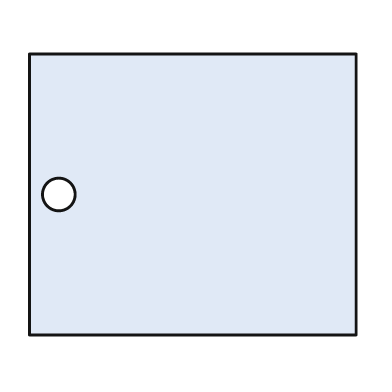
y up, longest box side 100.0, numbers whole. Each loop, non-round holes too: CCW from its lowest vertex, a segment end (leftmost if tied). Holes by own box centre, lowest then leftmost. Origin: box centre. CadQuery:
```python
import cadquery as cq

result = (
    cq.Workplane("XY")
    .moveTo(-50.0, -43.0)
    .lineTo(50.0, -43.0)
    .lineTo(50.0, 43.0)
    .lineTo(-50.0, 43.0)
    .close()
    .moveTo(-41.0, 0.0)
    .circle(5.0)
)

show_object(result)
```